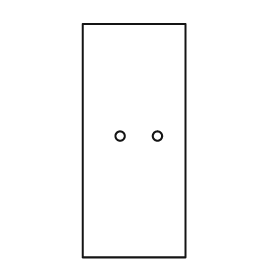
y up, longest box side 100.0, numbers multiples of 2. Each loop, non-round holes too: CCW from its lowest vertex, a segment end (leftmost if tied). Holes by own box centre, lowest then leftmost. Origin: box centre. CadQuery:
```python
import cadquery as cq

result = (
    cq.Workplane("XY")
    .moveTo(-22.0, -50.0)
    .lineTo(22.0, -50.0)
    .lineTo(22.0, 50.0)
    .lineTo(-22.0, 50.0)
    .close()
    .moveTo(-6.0, 2.0)
    .circle(2.0)
    .moveTo(10.0, 2.0)
    .circle(2.0)
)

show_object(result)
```